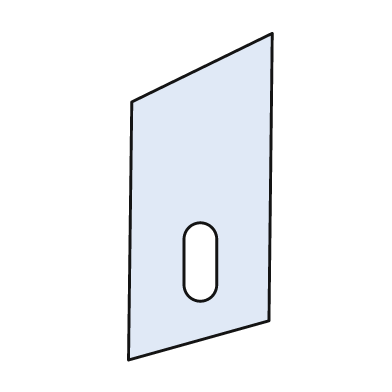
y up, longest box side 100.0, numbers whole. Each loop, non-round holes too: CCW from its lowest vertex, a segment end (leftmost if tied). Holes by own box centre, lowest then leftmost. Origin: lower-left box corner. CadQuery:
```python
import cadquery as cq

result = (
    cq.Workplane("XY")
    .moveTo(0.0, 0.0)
    .lineTo(43.0, 12.0)
    .lineTo(44.0, 100.0)
    .lineTo(1.0, 79.0)
    .close()
    .moveTo(17.0, 23.0)
    .threePointArc((22.0, 18.0), (27.0, 23.0))
    .lineTo(27.0, 37.0)
    .threePointArc((22.0, 42.0), (17.0, 37.0))
    .close()
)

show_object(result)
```